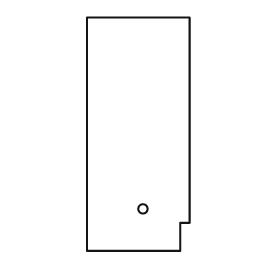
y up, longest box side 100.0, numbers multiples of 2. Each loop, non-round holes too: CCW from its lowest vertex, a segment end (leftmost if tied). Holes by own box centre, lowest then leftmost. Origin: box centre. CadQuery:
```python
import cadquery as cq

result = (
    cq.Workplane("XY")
    .moveTo(-22.0, -50.0)
    .lineTo(18.0, -50.0)
    .lineTo(18.0, -38.0)
    .lineTo(22.0, -38.0)
    .lineTo(22.0, 50.0)
    .lineTo(-22.0, 50.0)
    .close()
    .moveTo(2.0, -32.0)
    .circle(2.0)
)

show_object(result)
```